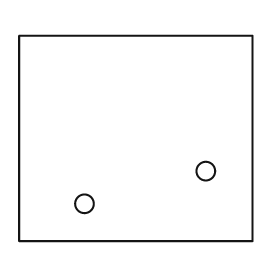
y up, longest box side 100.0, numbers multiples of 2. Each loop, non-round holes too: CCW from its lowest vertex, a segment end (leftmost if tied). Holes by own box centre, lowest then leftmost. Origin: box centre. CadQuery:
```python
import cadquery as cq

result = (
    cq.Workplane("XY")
    .moveTo(-50.0, -44.0)
    .lineTo(50.0, -44.0)
    .lineTo(50.0, 44.0)
    .lineTo(-50.0, 44.0)
    .close()
    .moveTo(-22.0, -28.0)
    .circle(4.0)
    .moveTo(30.0, -14.0)
    .circle(4.0)
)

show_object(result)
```